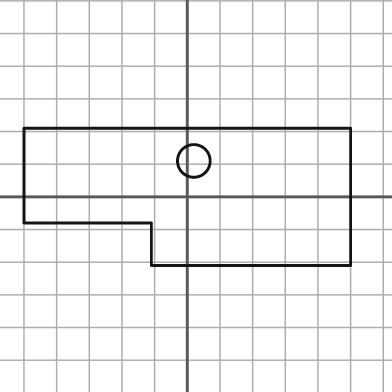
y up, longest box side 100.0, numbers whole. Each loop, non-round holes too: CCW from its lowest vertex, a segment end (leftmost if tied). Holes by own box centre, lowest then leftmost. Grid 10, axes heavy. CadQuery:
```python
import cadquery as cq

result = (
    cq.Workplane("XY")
    .moveTo(-11.0, -21.0)
    .lineTo(50.0, -21.0)
    .lineTo(50.0, 21.0)
    .lineTo(-50.0, 21.0)
    .lineTo(-50.0, -8.0)
    .lineTo(-11.0, -8.0)
    .close()
    .moveTo(2.0, 11.0)
    .circle(5.0)
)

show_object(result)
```